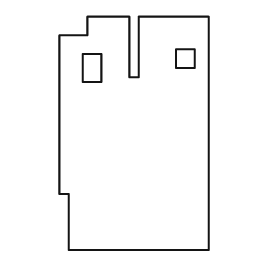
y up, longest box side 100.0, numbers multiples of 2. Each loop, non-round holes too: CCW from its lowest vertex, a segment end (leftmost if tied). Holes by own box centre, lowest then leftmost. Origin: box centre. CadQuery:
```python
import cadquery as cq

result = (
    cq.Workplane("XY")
    .moveTo(-28.0, -50.0)
    .lineTo(32.0, -50.0)
    .lineTo(32.0, 50.0)
    .lineTo(2.0, 50.0)
    .lineTo(2.0, 24.0)
    .lineTo(-2.0, 24.0)
    .lineTo(-2.0, 50.0)
    .lineTo(-20.0, 50.0)
    .lineTo(-20.0, 42.0)
    .lineTo(-32.0, 42.0)
    .lineTo(-32.0, -26.0)
    .lineTo(-28.0, -26.0)
    .close()
    .moveTo(-22.0, 22.0)
    .lineTo(-14.0, 22.0)
    .lineTo(-14.0, 34.0)
    .lineTo(-22.0, 34.0)
    .close()
    .moveTo(18.0, 28.0)
    .lineTo(26.0, 28.0)
    .lineTo(26.0, 36.0)
    .lineTo(18.0, 36.0)
    .close()
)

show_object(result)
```